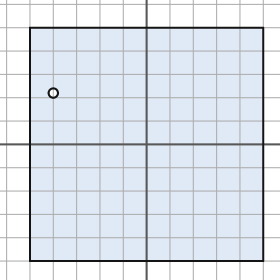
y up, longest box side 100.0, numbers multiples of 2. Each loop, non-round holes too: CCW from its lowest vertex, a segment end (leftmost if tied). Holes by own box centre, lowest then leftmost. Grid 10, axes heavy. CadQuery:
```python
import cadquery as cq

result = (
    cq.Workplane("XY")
    .moveTo(-50.0, -50.0)
    .lineTo(50.0, -50.0)
    .lineTo(50.0, 50.0)
    .lineTo(-50.0, 50.0)
    .close()
    .moveTo(-40.0, 22.0)
    .circle(2.0)
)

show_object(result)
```